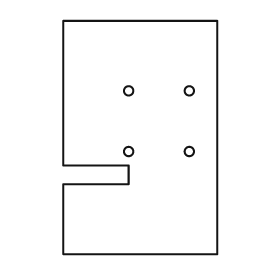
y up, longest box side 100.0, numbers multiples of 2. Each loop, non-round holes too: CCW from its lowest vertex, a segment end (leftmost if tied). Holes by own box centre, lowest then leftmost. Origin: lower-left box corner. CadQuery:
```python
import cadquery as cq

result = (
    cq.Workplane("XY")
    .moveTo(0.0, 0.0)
    .lineTo(66.0, 0.0)
    .lineTo(66.0, 100.0)
    .lineTo(0.0, 100.0)
    .lineTo(0.0, 38.0)
    .lineTo(28.0, 38.0)
    .lineTo(28.0, 30.0)
    .lineTo(0.0, 30.0)
    .close()
    .moveTo(28.0, 44.0)
    .circle(2.0)
    .moveTo(54.0, 44.0)
    .circle(2.0)
    .moveTo(28.0, 70.0)
    .circle(2.0)
    .moveTo(54.0, 70.0)
    .circle(2.0)
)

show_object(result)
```